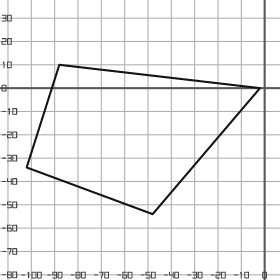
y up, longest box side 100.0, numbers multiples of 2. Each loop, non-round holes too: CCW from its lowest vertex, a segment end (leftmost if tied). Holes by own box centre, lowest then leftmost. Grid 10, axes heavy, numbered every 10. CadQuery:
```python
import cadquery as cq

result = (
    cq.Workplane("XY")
    .moveTo(-48.0, -54.0)
    .lineTo(-2.0, 0.0)
    .lineTo(-88.0, 10.0)
    .lineTo(-102.0, -34.0)
    .close()
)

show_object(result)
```